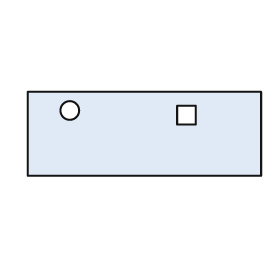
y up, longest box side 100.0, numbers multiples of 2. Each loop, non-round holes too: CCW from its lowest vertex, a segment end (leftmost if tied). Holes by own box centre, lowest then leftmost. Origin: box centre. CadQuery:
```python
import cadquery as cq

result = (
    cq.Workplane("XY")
    .moveTo(-50.0, -18.0)
    .lineTo(50.0, -18.0)
    .lineTo(50.0, 18.0)
    .lineTo(-50.0, 18.0)
    .close()
    .moveTo(14.0, 4.0)
    .lineTo(22.0, 4.0)
    .lineTo(22.0, 12.0)
    .lineTo(14.0, 12.0)
    .close()
    .moveTo(-32.0, 10.0)
    .circle(4.0)
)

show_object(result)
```